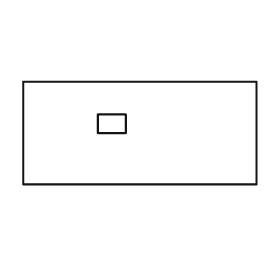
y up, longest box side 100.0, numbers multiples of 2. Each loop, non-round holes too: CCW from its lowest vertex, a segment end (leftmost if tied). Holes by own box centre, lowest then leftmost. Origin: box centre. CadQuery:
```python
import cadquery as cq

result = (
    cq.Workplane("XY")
    .moveTo(-50.0, -22.0)
    .lineTo(50.0, -22.0)
    .lineTo(50.0, 22.0)
    .lineTo(-50.0, 22.0)
    .close()
    .moveTo(-18.0, 0.0)
    .lineTo(-6.0, 0.0)
    .lineTo(-6.0, 8.0)
    .lineTo(-18.0, 8.0)
    .close()
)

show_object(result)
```